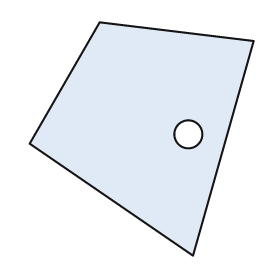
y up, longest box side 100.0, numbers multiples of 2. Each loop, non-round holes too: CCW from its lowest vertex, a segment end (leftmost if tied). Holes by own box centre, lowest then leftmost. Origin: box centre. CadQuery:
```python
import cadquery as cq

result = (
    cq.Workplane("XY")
    .moveTo(22.0, -50.0)
    .lineTo(48.0, 42.0)
    .lineTo(-18.0, 50.0)
    .lineTo(-48.0, -2.0)
    .close()
    .moveTo(20.0, 2.0)
    .circle(6.0)
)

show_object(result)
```